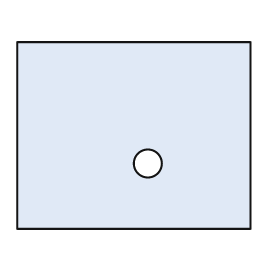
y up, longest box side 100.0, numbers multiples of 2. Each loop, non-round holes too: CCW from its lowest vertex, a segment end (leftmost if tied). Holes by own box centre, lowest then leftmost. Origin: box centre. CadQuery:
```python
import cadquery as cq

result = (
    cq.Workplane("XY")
    .moveTo(-50.0, -40.0)
    .lineTo(50.0, -40.0)
    .lineTo(50.0, 40.0)
    .lineTo(-50.0, 40.0)
    .close()
    .moveTo(6.0, -12.0)
    .circle(6.0)
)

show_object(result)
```